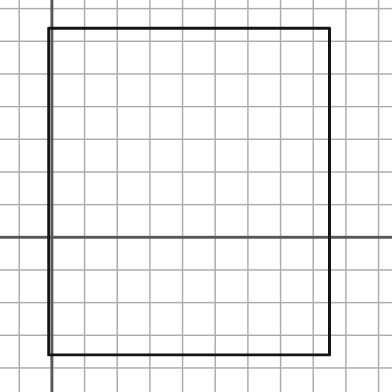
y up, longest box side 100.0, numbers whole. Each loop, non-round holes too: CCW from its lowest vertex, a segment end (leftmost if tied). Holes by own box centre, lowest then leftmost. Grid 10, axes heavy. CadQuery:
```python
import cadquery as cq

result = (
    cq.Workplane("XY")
    .moveTo(-1.0, -36.0)
    .lineTo(85.0, -36.0)
    .lineTo(85.0, 64.0)
    .lineTo(-1.0, 64.0)
    .close()
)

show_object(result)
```